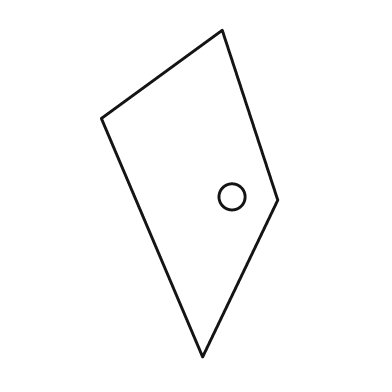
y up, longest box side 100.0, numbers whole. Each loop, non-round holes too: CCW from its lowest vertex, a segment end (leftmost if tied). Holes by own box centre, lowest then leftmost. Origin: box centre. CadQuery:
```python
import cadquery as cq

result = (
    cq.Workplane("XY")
    .moveTo(4.0, -50.0)
    .lineTo(27.0, -2.0)
    .lineTo(10.0, 50.0)
    .lineTo(-27.0, 23.0)
    .close()
    .moveTo(13.0, -1.0)
    .circle(4.0)
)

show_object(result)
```